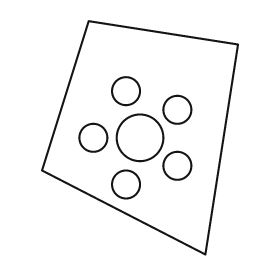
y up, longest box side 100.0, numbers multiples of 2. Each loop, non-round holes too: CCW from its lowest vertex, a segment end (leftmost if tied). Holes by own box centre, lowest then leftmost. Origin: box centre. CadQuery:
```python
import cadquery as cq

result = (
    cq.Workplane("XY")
    .moveTo(28.0, -50.0)
    .lineTo(42.0, 40.0)
    .lineTo(-22.0, 50.0)
    .lineTo(-42.0, -14.0)
    .close()
    .moveTo(-6.0, -20.0)
    .circle(6.0)
    .moveTo(16.0, -12.0)
    .circle(6.0)
    .moveTo(-20.0, 0.0)
    .circle(6.0)
    .moveTo(0.0, 0.0)
    .circle(10.0)
    .moveTo(16.0, 12.0)
    .circle(6.0)
    .moveTo(-6.0, 20.0)
    .circle(6.0)
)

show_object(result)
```